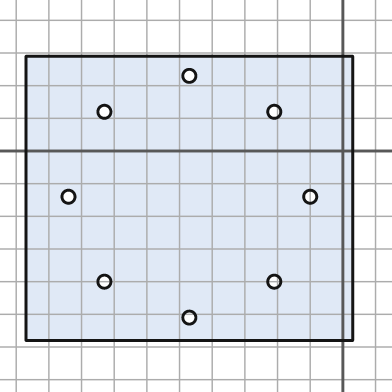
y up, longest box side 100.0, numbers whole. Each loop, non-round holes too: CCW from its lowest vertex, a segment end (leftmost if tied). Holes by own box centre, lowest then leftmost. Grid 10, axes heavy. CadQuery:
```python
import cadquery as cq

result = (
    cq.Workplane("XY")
    .moveTo(-97.0, -58.0)
    .lineTo(3.0, -58.0)
    .lineTo(3.0, 29.0)
    .lineTo(-97.0, 29.0)
    .close()
    .moveTo(-47.0, -51.0)
    .circle(2.0)
    .moveTo(-73.0, -40.0)
    .circle(2.0)
    .moveTo(-21.0, -40.0)
    .circle(2.0)
    .moveTo(-84.0, -14.0)
    .circle(2.0)
    .moveTo(-10.0, -14.0)
    .circle(2.0)
    .moveTo(-73.0, 12.0)
    .circle(2.0)
    .moveTo(-21.0, 12.0)
    .circle(2.0)
    .moveTo(-47.0, 23.0)
    .circle(2.0)
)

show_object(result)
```